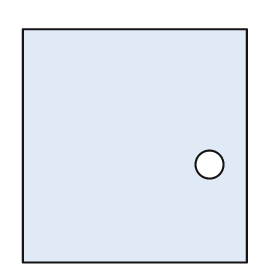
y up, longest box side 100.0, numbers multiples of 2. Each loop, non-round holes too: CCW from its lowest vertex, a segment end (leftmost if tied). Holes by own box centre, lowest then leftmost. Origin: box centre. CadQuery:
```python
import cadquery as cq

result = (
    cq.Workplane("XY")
    .moveTo(-48.0, -50.0)
    .lineTo(48.0, -50.0)
    .lineTo(48.0, 50.0)
    .lineTo(-48.0, 50.0)
    .close()
    .moveTo(32.0, -8.0)
    .circle(6.0)
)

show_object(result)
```